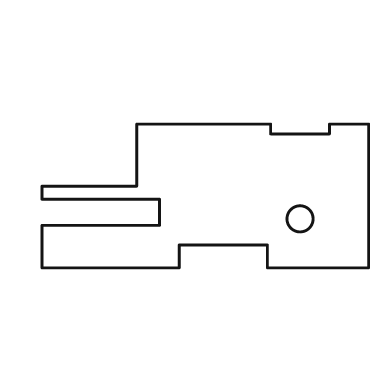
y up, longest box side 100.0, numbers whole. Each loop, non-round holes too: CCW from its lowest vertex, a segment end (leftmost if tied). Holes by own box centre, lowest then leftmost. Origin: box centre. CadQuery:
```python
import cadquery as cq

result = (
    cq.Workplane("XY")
    .moveTo(-50.0, -22.0)
    .lineTo(-8.0, -22.0)
    .lineTo(-8.0, -15.0)
    .lineTo(19.0, -15.0)
    .lineTo(19.0, -22.0)
    .lineTo(50.0, -22.0)
    .lineTo(50.0, 22.0)
    .lineTo(38.0, 22.0)
    .lineTo(38.0, 19.0)
    .lineTo(20.0, 19.0)
    .lineTo(20.0, 22.0)
    .lineTo(-21.0, 22.0)
    .lineTo(-21.0, 3.0)
    .lineTo(-50.0, 3.0)
    .lineTo(-50.0, -1.0)
    .lineTo(-14.0, -1.0)
    .lineTo(-14.0, -9.0)
    .lineTo(-50.0, -9.0)
    .close()
    .moveTo(29.0, -7.0)
    .circle(4.0)
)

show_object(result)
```